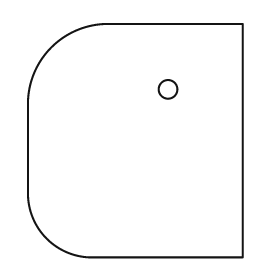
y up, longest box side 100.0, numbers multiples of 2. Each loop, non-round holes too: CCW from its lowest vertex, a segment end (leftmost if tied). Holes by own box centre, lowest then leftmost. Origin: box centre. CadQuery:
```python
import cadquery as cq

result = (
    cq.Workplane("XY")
    .moveTo(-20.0, -50.0)
    .lineTo(46.0, -50.0)
    .lineTo(46.0, 50.0)
    .lineTo(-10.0, 50.0)
    .threePointArc((-36.0, 40.0), (-46.0, 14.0))
    .lineTo(-46.0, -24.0)
    .threePointArc((-38.0, -42.0), (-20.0, -50.0))
    .close()
    .moveTo(14.0, 22.0)
    .circle(4.0)
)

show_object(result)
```